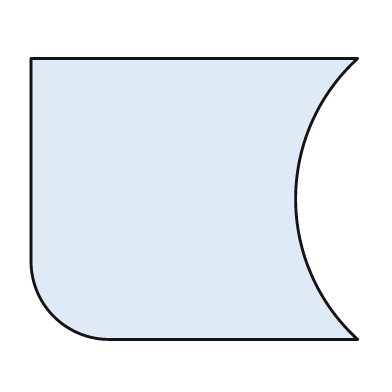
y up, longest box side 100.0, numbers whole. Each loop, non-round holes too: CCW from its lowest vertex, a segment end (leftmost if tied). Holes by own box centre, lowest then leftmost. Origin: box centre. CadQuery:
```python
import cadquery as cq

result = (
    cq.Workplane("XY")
    .moveTo(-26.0, -43.0)
    .lineTo(50.0, -43.0)
    .threePointArc((31.0, 0.0), (50.0, 43.0))
    .lineTo(-50.0, 43.0)
    .lineTo(-50.0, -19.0)
    .threePointArc((-43.0, -36.0), (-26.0, -43.0))
    .close()
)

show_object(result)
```